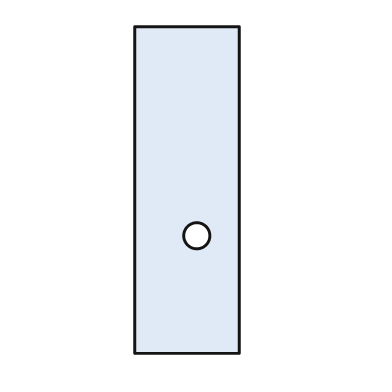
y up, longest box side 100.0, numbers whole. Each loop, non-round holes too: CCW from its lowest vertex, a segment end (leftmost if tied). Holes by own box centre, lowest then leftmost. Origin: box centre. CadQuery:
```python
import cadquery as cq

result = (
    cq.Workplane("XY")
    .moveTo(-16.0, -50.0)
    .lineTo(16.0, -50.0)
    .lineTo(16.0, 50.0)
    .lineTo(-16.0, 50.0)
    .close()
    .moveTo(3.0, -14.0)
    .circle(4.0)
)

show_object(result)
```